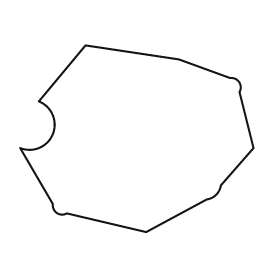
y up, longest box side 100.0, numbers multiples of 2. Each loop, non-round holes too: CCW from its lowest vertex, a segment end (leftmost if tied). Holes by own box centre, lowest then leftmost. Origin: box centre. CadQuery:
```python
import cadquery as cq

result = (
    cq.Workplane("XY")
    .moveTo(4.0, -40.0)
    .lineTo(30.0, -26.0)
    .threePointArc((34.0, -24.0), (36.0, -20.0))
    .lineTo(50.0, -4.0)
    .lineTo(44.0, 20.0)
    .threePointArc((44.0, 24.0), (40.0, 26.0))
    .lineTo(18.0, 34.0)
    .lineTo(-22.0, 40.0)
    .lineTo(-42.0, 16.0)
    .threePointArc((-36.0, 2.0), (-50.0, -4.0))
    .lineTo(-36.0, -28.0)
    .threePointArc((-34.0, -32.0), (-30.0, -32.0))
    .close()
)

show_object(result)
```